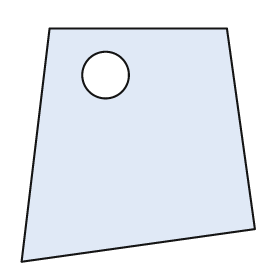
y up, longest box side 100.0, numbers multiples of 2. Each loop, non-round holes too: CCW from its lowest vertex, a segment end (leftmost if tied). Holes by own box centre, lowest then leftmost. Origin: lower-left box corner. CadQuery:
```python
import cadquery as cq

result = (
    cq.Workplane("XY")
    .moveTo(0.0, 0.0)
    .lineTo(100.0, 14.0)
    .lineTo(88.0, 100.0)
    .lineTo(12.0, 100.0)
    .close()
    .moveTo(36.0, 80.0)
    .circle(10.0)
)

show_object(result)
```